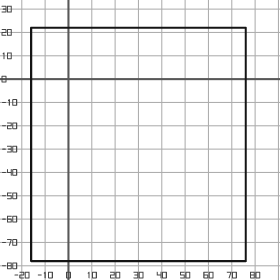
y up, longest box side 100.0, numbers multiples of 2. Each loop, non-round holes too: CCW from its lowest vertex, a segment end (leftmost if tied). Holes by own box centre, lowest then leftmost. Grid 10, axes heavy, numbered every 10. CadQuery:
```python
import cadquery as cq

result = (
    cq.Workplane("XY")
    .moveTo(-16.0, -78.0)
    .lineTo(76.0, -78.0)
    .lineTo(76.0, 22.0)
    .lineTo(-16.0, 22.0)
    .close()
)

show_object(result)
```